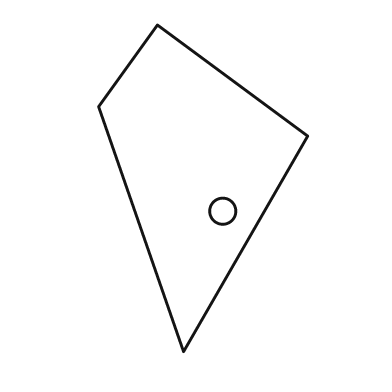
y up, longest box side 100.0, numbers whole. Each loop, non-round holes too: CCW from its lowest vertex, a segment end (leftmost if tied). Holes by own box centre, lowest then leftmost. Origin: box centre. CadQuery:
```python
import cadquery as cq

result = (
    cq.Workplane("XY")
    .moveTo(-6.0, -50.0)
    .lineTo(32.0, 16.0)
    .lineTo(-14.0, 50.0)
    .lineTo(-32.0, 25.0)
    .close()
    .moveTo(6.0, -7.0)
    .circle(4.0)
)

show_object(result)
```